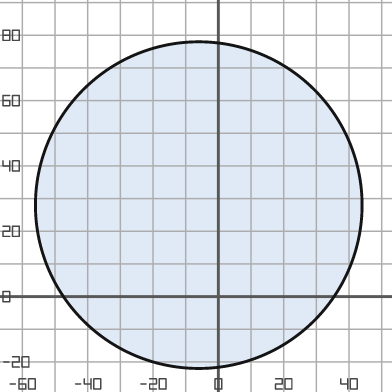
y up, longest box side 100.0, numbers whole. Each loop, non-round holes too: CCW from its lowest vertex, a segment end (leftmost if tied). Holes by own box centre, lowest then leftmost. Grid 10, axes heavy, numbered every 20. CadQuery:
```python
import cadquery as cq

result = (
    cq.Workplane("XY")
    .moveTo(-6.0, 28.0)
    .circle(50.0)
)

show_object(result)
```